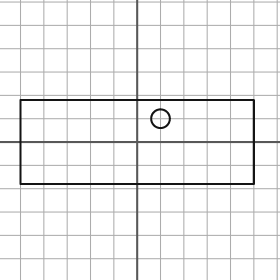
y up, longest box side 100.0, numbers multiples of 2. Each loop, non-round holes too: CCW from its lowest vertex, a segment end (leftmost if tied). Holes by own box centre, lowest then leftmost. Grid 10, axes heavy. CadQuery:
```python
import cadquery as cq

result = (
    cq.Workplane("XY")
    .moveTo(-50.0, -18.0)
    .lineTo(50.0, -18.0)
    .lineTo(50.0, 18.0)
    .lineTo(-50.0, 18.0)
    .close()
    .moveTo(10.0, 10.0)
    .circle(4.0)
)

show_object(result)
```